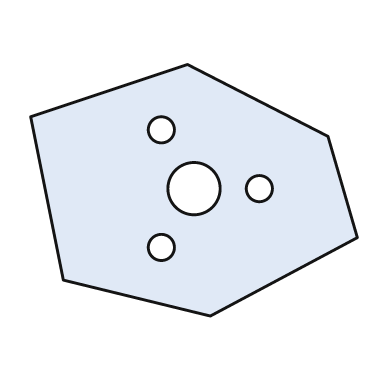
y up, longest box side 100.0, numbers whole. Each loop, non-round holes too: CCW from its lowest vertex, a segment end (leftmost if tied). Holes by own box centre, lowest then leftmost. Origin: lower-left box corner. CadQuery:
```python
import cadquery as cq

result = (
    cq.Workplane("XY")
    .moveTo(55.0, 0.0)
    .lineTo(100.0, 24.0)
    .lineTo(91.0, 55.0)
    .lineTo(48.0, 77.0)
    .lineTo(0.0, 61.0)
    .lineTo(10.0, 11.0)
    .close()
    .moveTo(40.0, 21.0)
    .circle(4.0)
    .moveTo(50.0, 39.0)
    .circle(8.0)
    .moveTo(70.0, 39.0)
    .circle(4.0)
    .moveTo(40.0, 57.0)
    .circle(4.0)
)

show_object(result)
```